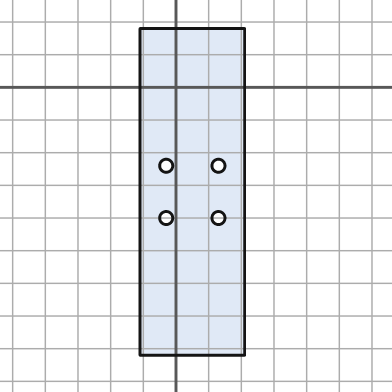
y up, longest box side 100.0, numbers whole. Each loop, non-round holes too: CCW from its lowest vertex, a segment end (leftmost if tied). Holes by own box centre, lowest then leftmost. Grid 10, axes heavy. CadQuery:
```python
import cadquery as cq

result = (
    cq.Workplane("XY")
    .moveTo(-11.0, -82.0)
    .lineTo(21.0, -82.0)
    .lineTo(21.0, 18.0)
    .lineTo(-11.0, 18.0)
    .close()
    .moveTo(-3.0, -40.0)
    .circle(2.0)
    .moveTo(13.0, -40.0)
    .circle(2.0)
    .moveTo(-3.0, -24.0)
    .circle(2.0)
    .moveTo(13.0, -24.0)
    .circle(2.0)
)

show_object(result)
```